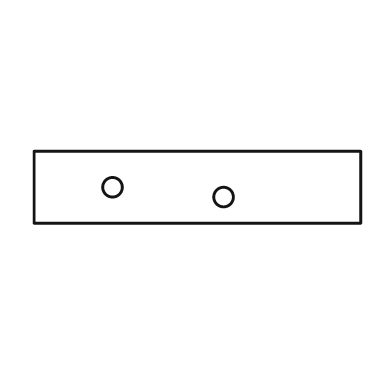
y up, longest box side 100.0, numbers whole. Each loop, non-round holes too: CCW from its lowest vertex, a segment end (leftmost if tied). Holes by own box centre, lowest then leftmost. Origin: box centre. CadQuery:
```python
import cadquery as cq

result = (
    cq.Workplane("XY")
    .moveTo(-50.0, -11.0)
    .lineTo(50.0, -11.0)
    .lineTo(50.0, 11.0)
    .lineTo(-50.0, 11.0)
    .close()
    .moveTo(8.0, -3.0)
    .circle(3.0)
    .moveTo(-26.0, 0.0)
    .circle(3.0)
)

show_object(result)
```